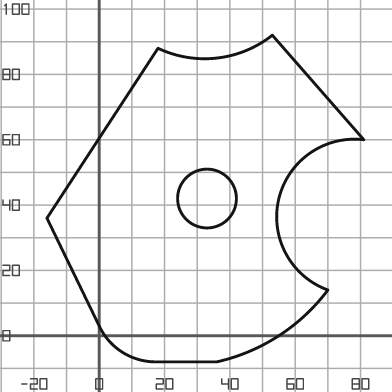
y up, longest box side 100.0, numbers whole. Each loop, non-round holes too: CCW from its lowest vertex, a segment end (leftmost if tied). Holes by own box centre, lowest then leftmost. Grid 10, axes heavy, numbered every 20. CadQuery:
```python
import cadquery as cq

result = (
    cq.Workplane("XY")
    .moveTo(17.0, -8.0)
    .lineTo(36.0, -8.0)
    .threePointArc((55.0, 0.0), (70.0, 14.0))
    .threePointArc((55.0, 42.0), (81.0, 60.0))
    .lineTo(53.0, 92.0)
    .threePointArc((36.0, 85.0), (18.0, 88.0))
    .lineTo(-16.0, 36.0)
    .lineTo(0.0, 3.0)
    .threePointArc((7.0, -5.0), (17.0, -8.0))
    .close()
    .moveTo(33.0, 42.0)
    .circle(9.0)
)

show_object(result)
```